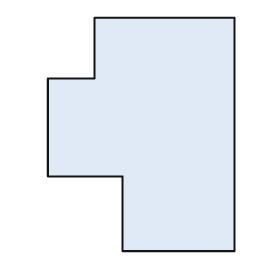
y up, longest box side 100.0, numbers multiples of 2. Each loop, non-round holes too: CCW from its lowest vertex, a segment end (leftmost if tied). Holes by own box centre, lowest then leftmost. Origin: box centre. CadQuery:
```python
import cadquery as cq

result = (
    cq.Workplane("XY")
    .moveTo(-8.0, -50.0)
    .lineTo(40.0, -50.0)
    .lineTo(40.0, 50.0)
    .lineTo(-20.0, 50.0)
    .lineTo(-20.0, 24.0)
    .lineTo(-40.0, 24.0)
    .lineTo(-40.0, -18.0)
    .lineTo(-8.0, -18.0)
    .close()
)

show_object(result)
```